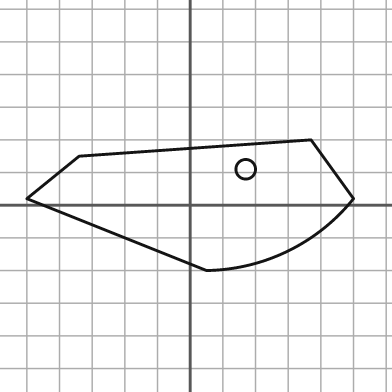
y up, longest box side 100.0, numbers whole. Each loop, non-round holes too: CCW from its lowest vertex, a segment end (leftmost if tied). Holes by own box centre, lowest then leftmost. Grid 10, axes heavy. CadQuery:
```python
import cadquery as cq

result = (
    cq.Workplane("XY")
    .moveTo(5.0, -20.0)
    .threePointArc((30.0, -14.0), (50.0, 2.0))
    .lineTo(37.0, 20.0)
    .lineTo(-34.0, 15.0)
    .lineTo(-50.0, 2.0)
    .close()
    .moveTo(17.0, 11.0)
    .circle(3.0)
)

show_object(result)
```